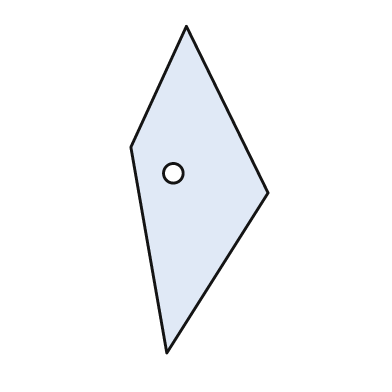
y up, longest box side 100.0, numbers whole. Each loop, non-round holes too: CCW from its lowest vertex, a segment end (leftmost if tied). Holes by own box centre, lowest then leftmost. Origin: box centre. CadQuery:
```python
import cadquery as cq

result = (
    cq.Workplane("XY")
    .moveTo(-10.0, -50.0)
    .lineTo(21.0, -1.0)
    .lineTo(-4.0, 50.0)
    .lineTo(-21.0, 13.0)
    .close()
    .moveTo(-8.0, 5.0)
    .circle(3.0)
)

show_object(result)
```